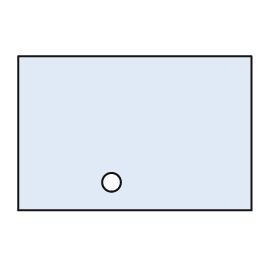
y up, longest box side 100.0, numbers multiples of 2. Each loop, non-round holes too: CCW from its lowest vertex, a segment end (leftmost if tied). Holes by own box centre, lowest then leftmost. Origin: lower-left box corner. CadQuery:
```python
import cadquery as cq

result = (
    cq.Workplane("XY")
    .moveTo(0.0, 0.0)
    .lineTo(100.0, 0.0)
    .lineTo(100.0, 66.0)
    .lineTo(0.0, 66.0)
    .close()
    .moveTo(40.0, 12.0)
    .circle(4.0)
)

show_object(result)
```